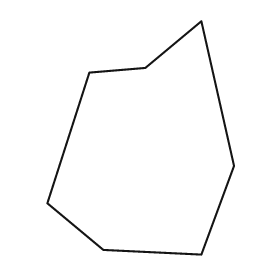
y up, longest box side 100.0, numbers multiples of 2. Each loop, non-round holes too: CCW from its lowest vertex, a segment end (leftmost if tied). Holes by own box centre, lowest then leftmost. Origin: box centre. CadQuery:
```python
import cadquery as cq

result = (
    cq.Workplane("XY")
    .moveTo(26.0, -50.0)
    .lineTo(40.0, -12.0)
    .lineTo(26.0, 50.0)
    .lineTo(2.0, 30.0)
    .lineTo(-22.0, 28.0)
    .lineTo(-40.0, -28.0)
    .lineTo(-16.0, -48.0)
    .close()
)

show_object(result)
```